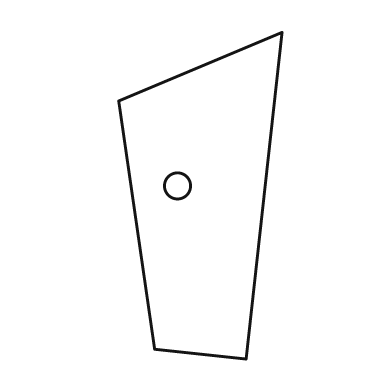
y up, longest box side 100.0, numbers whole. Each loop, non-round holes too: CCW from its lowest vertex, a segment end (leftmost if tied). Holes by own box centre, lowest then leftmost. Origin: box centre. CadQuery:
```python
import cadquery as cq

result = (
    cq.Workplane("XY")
    .moveTo(14.0, -50.0)
    .lineTo(25.0, 50.0)
    .lineTo(-25.0, 29.0)
    .lineTo(-14.0, -47.0)
    .close()
    .moveTo(-7.0, 3.0)
    .circle(4.0)
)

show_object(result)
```